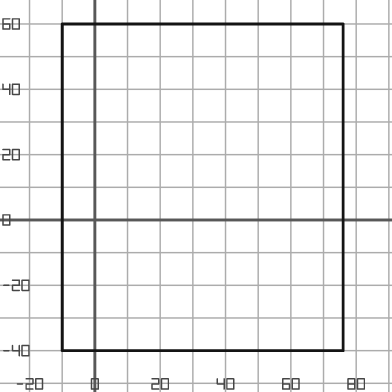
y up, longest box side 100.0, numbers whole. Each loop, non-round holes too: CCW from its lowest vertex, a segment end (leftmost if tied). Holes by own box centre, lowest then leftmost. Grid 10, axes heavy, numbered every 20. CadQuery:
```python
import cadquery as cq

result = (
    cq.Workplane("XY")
    .moveTo(-10.0, -40.0)
    .lineTo(76.0, -40.0)
    .lineTo(76.0, 60.0)
    .lineTo(-10.0, 60.0)
    .close()
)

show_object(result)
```